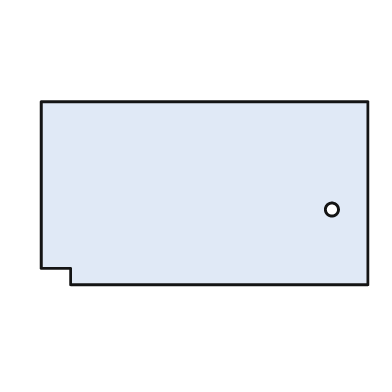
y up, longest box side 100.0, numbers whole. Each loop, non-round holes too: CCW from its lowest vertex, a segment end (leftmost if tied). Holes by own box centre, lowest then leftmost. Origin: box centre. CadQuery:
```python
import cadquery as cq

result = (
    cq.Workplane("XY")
    .moveTo(-41.0, -28.0)
    .lineTo(50.0, -28.0)
    .lineTo(50.0, 28.0)
    .lineTo(-50.0, 28.0)
    .lineTo(-50.0, -23.0)
    .lineTo(-41.0, -23.0)
    .close()
    .moveTo(39.0, -5.0)
    .circle(2.0)
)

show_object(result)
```